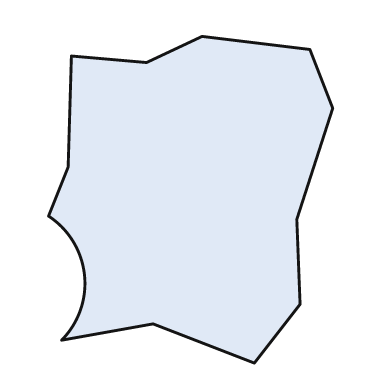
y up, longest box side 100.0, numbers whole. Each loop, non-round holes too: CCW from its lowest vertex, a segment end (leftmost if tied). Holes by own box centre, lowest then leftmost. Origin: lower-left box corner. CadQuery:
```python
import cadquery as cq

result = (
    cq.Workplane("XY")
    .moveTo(63.0, 0.0)
    .lineTo(77.0, 18.0)
    .lineTo(76.0, 44.0)
    .lineTo(87.0, 78.0)
    .lineTo(80.0, 96.0)
    .lineTo(47.0, 100.0)
    .lineTo(30.0, 92.0)
    .lineTo(7.0, 94.0)
    .lineTo(6.0, 60.0)
    .lineTo(0.0, 45.0)
    .threePointArc((11.0, 27.0), (4.0, 7.0))
    .lineTo(32.0, 12.0)
    .close()
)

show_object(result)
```